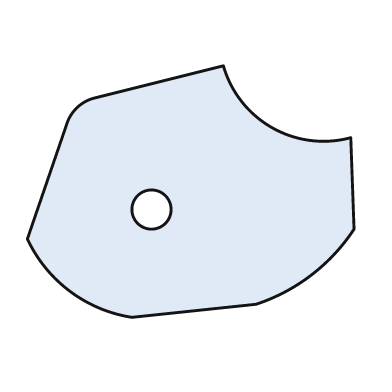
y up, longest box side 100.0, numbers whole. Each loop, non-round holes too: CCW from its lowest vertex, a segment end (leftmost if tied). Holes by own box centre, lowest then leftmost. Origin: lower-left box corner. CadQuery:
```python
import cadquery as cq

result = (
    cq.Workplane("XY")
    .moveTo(32.0, 0.0)
    .lineTo(70.0, 4.0)
    .threePointArc((87.0, 13.0), (100.0, 27.0))
    .lineTo(99.0, 55.0)
    .threePointArc((75.0, 58.0), (60.0, 77.0))
    .lineTo(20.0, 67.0)
    .threePointArc((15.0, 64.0), (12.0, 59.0))
    .lineTo(0.0, 24.0)
    .threePointArc((13.0, 8.0), (32.0, 0.0))
    .close()
    .moveTo(38.0, 33.0)
    .circle(6.0)
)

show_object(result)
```